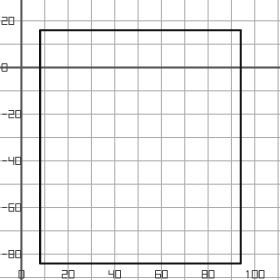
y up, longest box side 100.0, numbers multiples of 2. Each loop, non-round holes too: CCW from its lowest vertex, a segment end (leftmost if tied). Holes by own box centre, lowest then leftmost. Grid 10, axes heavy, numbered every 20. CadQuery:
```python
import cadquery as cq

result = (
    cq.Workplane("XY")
    .moveTo(8.0, -84.0)
    .lineTo(94.0, -84.0)
    .lineTo(94.0, 16.0)
    .lineTo(8.0, 16.0)
    .close()
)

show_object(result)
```